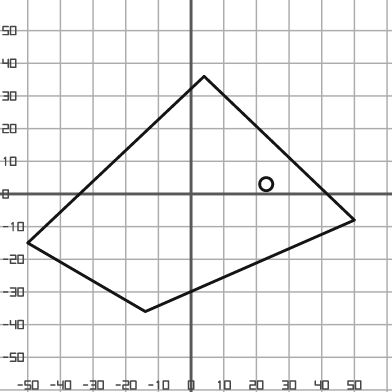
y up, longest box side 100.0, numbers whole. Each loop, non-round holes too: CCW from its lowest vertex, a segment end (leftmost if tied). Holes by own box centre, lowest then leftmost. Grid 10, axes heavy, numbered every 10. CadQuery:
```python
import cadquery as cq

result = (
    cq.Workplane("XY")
    .moveTo(-14.0, -36.0)
    .lineTo(50.0, -8.0)
    .lineTo(4.0, 36.0)
    .lineTo(-50.0, -15.0)
    .close()
    .moveTo(23.0, 3.0)
    .circle(2.0)
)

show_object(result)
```